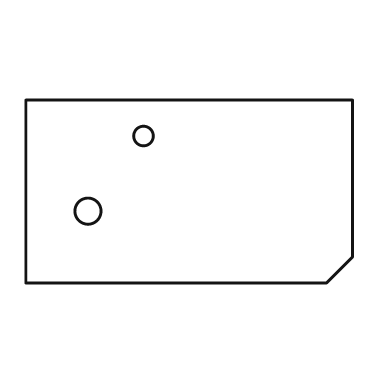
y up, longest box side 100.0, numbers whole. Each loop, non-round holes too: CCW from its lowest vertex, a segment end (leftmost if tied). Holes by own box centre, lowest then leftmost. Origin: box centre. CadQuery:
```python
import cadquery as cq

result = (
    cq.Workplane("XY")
    .moveTo(-50.0, -28.0)
    .lineTo(42.0, -28.0)
    .lineTo(50.0, -20.0)
    .lineTo(50.0, 28.0)
    .lineTo(-50.0, 28.0)
    .close()
    .moveTo(-31.0, -6.0)
    .circle(4.0)
    .moveTo(-14.0, 17.0)
    .circle(3.0)
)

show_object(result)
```